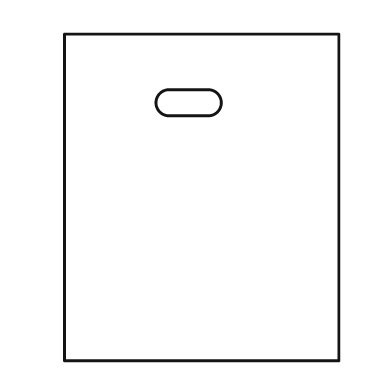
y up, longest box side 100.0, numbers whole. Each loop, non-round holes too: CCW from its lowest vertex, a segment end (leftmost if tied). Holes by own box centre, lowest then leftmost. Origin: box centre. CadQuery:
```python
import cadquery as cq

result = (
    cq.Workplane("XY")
    .moveTo(-42.0, -50.0)
    .lineTo(42.0, -50.0)
    .lineTo(42.0, 50.0)
    .lineTo(-42.0, 50.0)
    .close()
    .moveTo(-10.0, 25.0)
    .lineTo(2.0, 25.0)
    .threePointArc((6.0, 29.0), (2.0, 33.0))
    .lineTo(-10.0, 33.0)
    .threePointArc((-14.0, 29.0), (-10.0, 25.0))
    .close()
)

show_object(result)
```